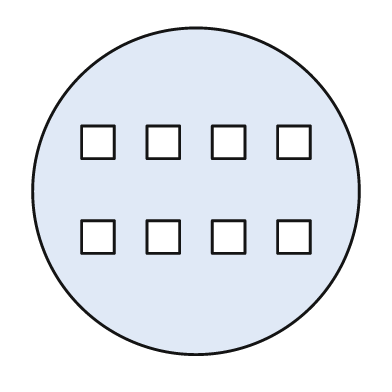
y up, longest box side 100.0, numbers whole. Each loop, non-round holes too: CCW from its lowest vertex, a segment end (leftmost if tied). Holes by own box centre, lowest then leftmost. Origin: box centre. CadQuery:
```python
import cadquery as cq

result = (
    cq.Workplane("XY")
    .moveTo(0.0, 0.0)
    .circle(50.0)
    .moveTo(-35.0, -19.0)
    .lineTo(-25.0, -19.0)
    .lineTo(-25.0, -9.0)
    .lineTo(-35.0, -9.0)
    .close()
    .moveTo(-15.0, -19.0)
    .lineTo(-5.0, -19.0)
    .lineTo(-5.0, -9.0)
    .lineTo(-15.0, -9.0)
    .close()
    .moveTo(5.0, -19.0)
    .lineTo(15.0, -19.0)
    .lineTo(15.0, -9.0)
    .lineTo(5.0, -9.0)
    .close()
    .moveTo(25.0, -19.0)
    .lineTo(35.0, -19.0)
    .lineTo(35.0, -9.0)
    .lineTo(25.0, -9.0)
    .close()
    .moveTo(-35.0, 10.0)
    .lineTo(-25.0, 10.0)
    .lineTo(-25.0, 20.0)
    .lineTo(-35.0, 20.0)
    .close()
    .moveTo(-15.0, 10.0)
    .lineTo(-5.0, 10.0)
    .lineTo(-5.0, 20.0)
    .lineTo(-15.0, 20.0)
    .close()
    .moveTo(5.0, 10.0)
    .lineTo(15.0, 10.0)
    .lineTo(15.0, 20.0)
    .lineTo(5.0, 20.0)
    .close()
    .moveTo(25.0, 10.0)
    .lineTo(35.0, 10.0)
    .lineTo(35.0, 20.0)
    .lineTo(25.0, 20.0)
    .close()
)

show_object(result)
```